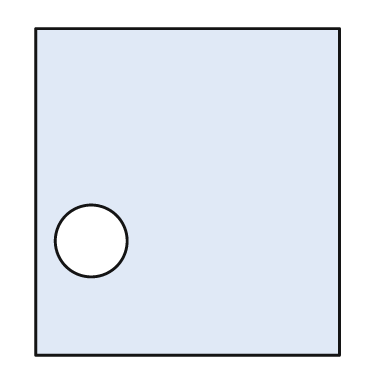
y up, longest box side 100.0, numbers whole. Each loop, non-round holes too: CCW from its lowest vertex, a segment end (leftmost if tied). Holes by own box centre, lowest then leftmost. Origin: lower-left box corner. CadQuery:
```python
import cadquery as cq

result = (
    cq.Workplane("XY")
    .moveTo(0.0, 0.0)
    .lineTo(93.0, 0.0)
    .lineTo(93.0, 100.0)
    .lineTo(0.0, 100.0)
    .close()
    .moveTo(17.0, 35.0)
    .circle(11.0)
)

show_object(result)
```